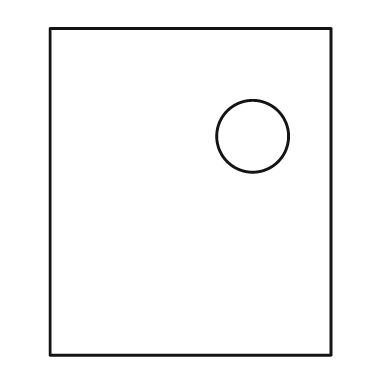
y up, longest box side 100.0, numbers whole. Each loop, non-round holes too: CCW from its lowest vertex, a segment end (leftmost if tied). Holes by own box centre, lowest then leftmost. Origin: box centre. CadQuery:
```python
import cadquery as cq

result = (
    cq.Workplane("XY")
    .moveTo(-43.0, -50.0)
    .lineTo(43.0, -50.0)
    .lineTo(43.0, 50.0)
    .lineTo(-43.0, 50.0)
    .close()
    .moveTo(19.0, 17.0)
    .circle(11.0)
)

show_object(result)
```